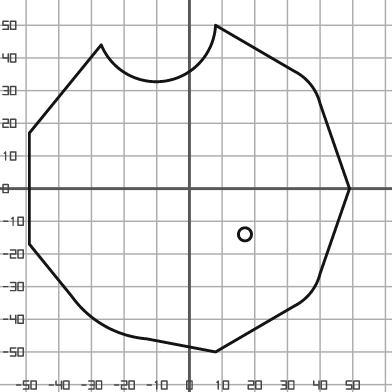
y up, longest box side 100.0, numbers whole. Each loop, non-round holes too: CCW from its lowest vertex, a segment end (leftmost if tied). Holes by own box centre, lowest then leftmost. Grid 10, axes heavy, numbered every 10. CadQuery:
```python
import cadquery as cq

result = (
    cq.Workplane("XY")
    .moveTo(8.0, -50.0)
    .lineTo(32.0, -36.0)
    .threePointArc((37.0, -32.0), (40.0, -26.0))
    .lineTo(49.0, 0.0)
    .lineTo(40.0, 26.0)
    .threePointArc((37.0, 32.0), (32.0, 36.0))
    .lineTo(8.0, 50.0)
    .threePointArc((-7.0, 33.0), (-27.0, 44.0))
    .lineTo(-49.0, 17.0)
    .lineTo(-49.0, -17.0)
    .lineTo(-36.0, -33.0)
    .threePointArc((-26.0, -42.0), (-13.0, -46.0))
    .close()
    .moveTo(17.0, -14.0)
    .circle(2.0)
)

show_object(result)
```